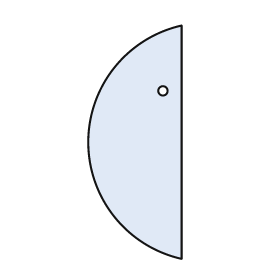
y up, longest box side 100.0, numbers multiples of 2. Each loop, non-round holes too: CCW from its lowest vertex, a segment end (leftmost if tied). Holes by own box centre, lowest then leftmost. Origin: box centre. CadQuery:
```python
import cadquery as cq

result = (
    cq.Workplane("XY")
    .moveTo(20.0, -50.0)
    .lineTo(20.0, 50.0)
    .threePointArc((-20.0, 0.0), (20.0, -50.0))
    .close()
    .moveTo(12.0, 22.0)
    .circle(2.0)
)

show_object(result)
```